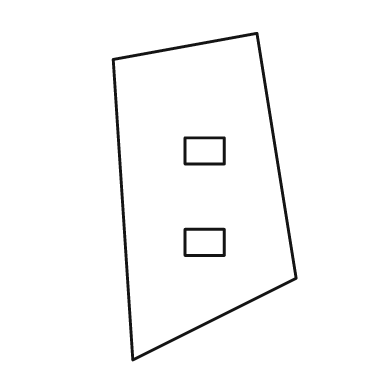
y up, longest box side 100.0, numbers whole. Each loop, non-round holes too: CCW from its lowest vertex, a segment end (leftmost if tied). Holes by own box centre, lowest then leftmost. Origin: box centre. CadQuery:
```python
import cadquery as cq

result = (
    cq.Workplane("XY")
    .moveTo(-22.0, -50.0)
    .lineTo(28.0, -25.0)
    .lineTo(16.0, 50.0)
    .lineTo(-28.0, 42.0)
    .close()
    .moveTo(-6.0, -18.0)
    .lineTo(6.0, -18.0)
    .lineTo(6.0, -10.0)
    .lineTo(-6.0, -10.0)
    .close()
    .moveTo(-6.0, 10.0)
    .lineTo(6.0, 10.0)
    .lineTo(6.0, 18.0)
    .lineTo(-6.0, 18.0)
    .close()
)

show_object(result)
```